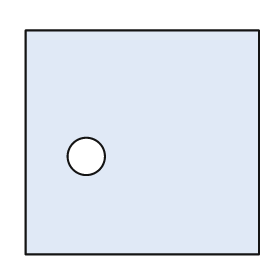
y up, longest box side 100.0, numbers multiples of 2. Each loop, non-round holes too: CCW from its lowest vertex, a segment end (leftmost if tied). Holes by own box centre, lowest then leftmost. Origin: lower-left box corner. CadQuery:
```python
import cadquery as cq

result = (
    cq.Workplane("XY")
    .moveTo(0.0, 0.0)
    .lineTo(100.0, 0.0)
    .lineTo(100.0, 96.0)
    .lineTo(0.0, 96.0)
    .close()
    .moveTo(26.0, 42.0)
    .circle(8.0)
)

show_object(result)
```